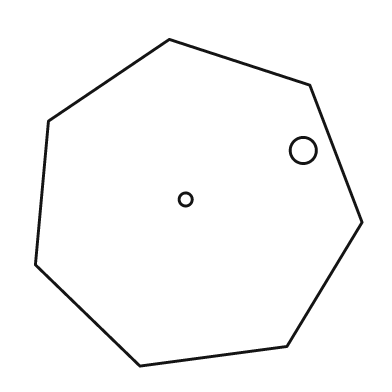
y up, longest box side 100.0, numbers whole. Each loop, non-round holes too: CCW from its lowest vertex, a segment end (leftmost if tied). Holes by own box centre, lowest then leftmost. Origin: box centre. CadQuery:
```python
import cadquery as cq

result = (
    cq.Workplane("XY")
    .moveTo(-18.0, -50.0)
    .lineTo(27.0, -44.0)
    .lineTo(50.0, -6.0)
    .lineTo(34.0, 36.0)
    .lineTo(-9.0, 50.0)
    .lineTo(-46.0, 25.0)
    .lineTo(-50.0, -19.0)
    .close()
    .moveTo(-4.0, 1.0)
    .circle(2.0)
    .moveTo(32.0, 16.0)
    .circle(4.0)
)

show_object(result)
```